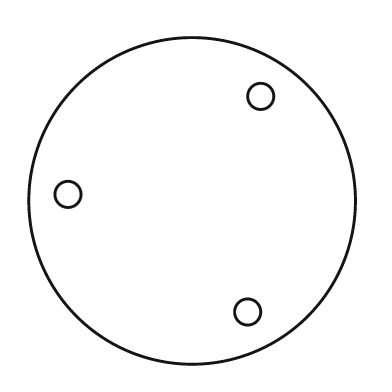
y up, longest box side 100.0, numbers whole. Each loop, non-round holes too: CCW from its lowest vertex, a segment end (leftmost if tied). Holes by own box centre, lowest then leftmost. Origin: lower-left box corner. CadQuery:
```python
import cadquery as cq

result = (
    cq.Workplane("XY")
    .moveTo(50.0, 50.0)
    .circle(50.0)
    .moveTo(67.0, 16.0)
    .circle(4.0)
    .moveTo(12.0, 52.0)
    .circle(4.0)
    .moveTo(71.0, 82.0)
    .circle(4.0)
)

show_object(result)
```